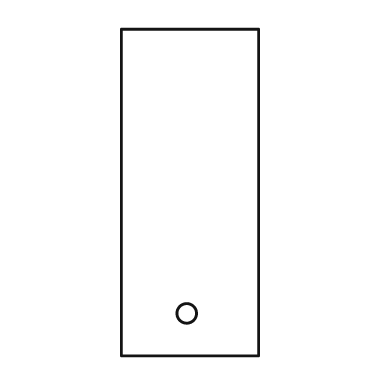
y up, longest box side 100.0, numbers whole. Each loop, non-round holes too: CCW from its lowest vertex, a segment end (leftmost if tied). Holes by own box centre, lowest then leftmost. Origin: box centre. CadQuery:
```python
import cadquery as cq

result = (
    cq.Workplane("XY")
    .moveTo(-21.0, -50.0)
    .lineTo(21.0, -50.0)
    .lineTo(21.0, 50.0)
    .lineTo(-21.0, 50.0)
    .close()
    .moveTo(-1.0, -37.0)
    .circle(3.0)
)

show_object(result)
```